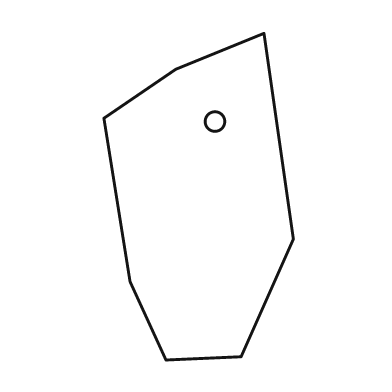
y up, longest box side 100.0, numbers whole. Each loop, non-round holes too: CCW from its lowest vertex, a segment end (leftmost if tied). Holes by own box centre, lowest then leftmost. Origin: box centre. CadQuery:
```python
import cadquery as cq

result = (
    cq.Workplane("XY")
    .moveTo(-10.0, -50.0)
    .lineTo(13.0, -49.0)
    .lineTo(29.0, -13.0)
    .lineTo(20.0, 50.0)
    .lineTo(-7.0, 39.0)
    .lineTo(-29.0, 24.0)
    .lineTo(-21.0, -26.0)
    .close()
    .moveTo(5.0, 23.0)
    .circle(3.0)
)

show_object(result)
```